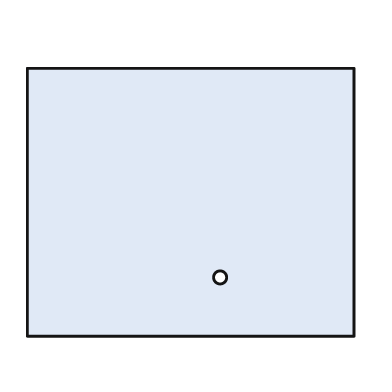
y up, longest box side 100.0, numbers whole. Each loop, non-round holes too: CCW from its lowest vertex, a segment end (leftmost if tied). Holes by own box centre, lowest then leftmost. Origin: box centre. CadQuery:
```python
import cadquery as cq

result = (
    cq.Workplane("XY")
    .moveTo(-50.0, -41.0)
    .lineTo(50.0, -41.0)
    .lineTo(50.0, 41.0)
    .lineTo(-50.0, 41.0)
    .close()
    .moveTo(9.0, -23.0)
    .circle(2.0)
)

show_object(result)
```